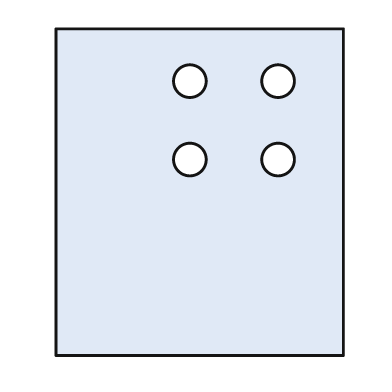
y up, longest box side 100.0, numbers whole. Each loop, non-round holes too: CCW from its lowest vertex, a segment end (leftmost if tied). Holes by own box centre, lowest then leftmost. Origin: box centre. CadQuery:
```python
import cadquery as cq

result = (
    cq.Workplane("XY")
    .moveTo(-44.0, -50.0)
    .lineTo(44.0, -50.0)
    .lineTo(44.0, 50.0)
    .lineTo(-44.0, 50.0)
    .close()
    .moveTo(-3.0, 10.0)
    .circle(5.0)
    .moveTo(24.0, 10.0)
    .circle(5.0)
    .moveTo(-3.0, 34.0)
    .circle(5.0)
    .moveTo(24.0, 34.0)
    .circle(5.0)
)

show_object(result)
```